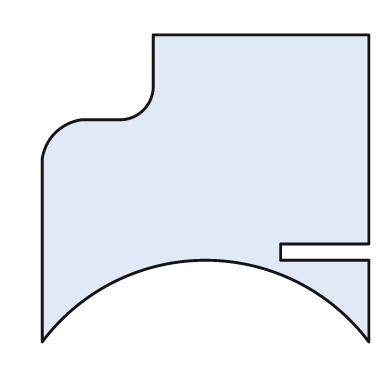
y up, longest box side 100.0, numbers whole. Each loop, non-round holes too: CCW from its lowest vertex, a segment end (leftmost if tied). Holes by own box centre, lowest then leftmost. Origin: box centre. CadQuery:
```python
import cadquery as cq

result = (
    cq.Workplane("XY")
    .moveTo(-50.0, -47.0)
    .threePointArc((0.0, -22.0), (50.0, -47.0))
    .lineTo(50.0, -22.0)
    .lineTo(23.0, -22.0)
    .lineTo(23.0, -17.0)
    .lineTo(50.0, -17.0)
    .lineTo(50.0, 47.0)
    .lineTo(-16.0, 47.0)
    .lineTo(-16.0, 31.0)
    .threePointArc((-19.0, 24.0), (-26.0, 21.0))
    .lineTo(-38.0, 21.0)
    .threePointArc((-46.0, 17.0), (-50.0, 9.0))
    .close()
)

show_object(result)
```